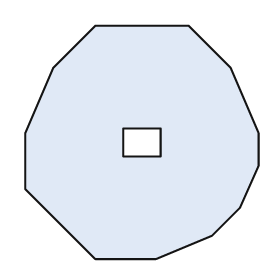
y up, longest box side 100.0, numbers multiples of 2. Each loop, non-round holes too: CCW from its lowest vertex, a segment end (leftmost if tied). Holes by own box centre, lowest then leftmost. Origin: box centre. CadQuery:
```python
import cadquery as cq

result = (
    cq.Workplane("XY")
    .moveTo(-20.0, -50.0)
    .lineTo(6.0, -50.0)
    .lineTo(30.0, -40.0)
    .lineTo(42.0, -28.0)
    .lineTo(50.0, -10.0)
    .lineTo(50.0, 4.0)
    .lineTo(38.0, 32.0)
    .lineTo(20.0, 50.0)
    .lineTo(-20.0, 50.0)
    .lineTo(-38.0, 32.0)
    .lineTo(-50.0, 4.0)
    .lineTo(-50.0, -20.0)
    .close()
    .moveTo(-8.0, -6.0)
    .lineTo(8.0, -6.0)
    .lineTo(8.0, 6.0)
    .lineTo(-8.0, 6.0)
    .close()
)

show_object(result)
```